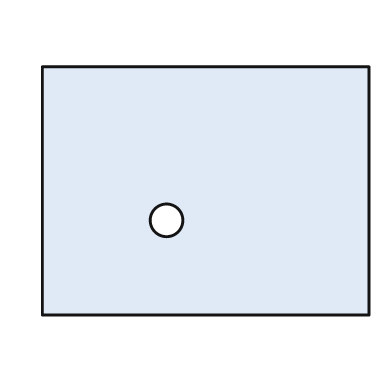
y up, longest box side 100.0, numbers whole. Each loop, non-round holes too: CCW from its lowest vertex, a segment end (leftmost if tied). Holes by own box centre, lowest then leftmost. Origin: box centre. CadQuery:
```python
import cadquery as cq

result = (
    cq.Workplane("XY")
    .moveTo(-50.0, -38.0)
    .lineTo(50.0, -38.0)
    .lineTo(50.0, 38.0)
    .lineTo(-50.0, 38.0)
    .close()
    .moveTo(-12.0, -9.0)
    .circle(5.0)
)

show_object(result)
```